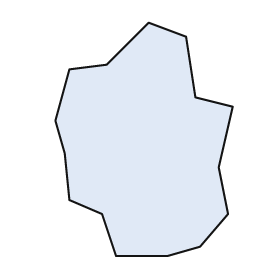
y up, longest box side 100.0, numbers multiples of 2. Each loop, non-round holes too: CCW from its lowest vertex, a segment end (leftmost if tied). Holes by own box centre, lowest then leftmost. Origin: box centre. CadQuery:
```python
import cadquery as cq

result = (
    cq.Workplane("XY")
    .moveTo(-12.0, -50.0)
    .lineTo(10.0, -50.0)
    .lineTo(24.0, -46.0)
    .lineTo(36.0, -32.0)
    .lineTo(32.0, -12.0)
    .lineTo(38.0, 14.0)
    .lineTo(22.0, 18.0)
    .lineTo(18.0, 44.0)
    .lineTo(2.0, 50.0)
    .lineTo(-16.0, 32.0)
    .lineTo(-32.0, 30.0)
    .lineTo(-38.0, 8.0)
    .lineTo(-34.0, -6.0)
    .lineTo(-32.0, -26.0)
    .lineTo(-18.0, -32.0)
    .close()
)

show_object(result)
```